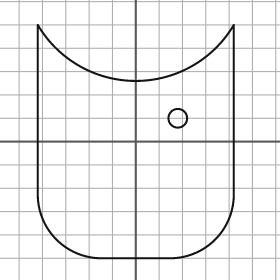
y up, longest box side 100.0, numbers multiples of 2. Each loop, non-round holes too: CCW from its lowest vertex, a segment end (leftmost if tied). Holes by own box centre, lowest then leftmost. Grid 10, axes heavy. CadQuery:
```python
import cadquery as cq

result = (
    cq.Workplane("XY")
    .moveTo(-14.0, -50.0)
    .lineTo(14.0, -50.0)
    .threePointArc((34.0, -42.0), (42.0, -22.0))
    .lineTo(42.0, 50.0)
    .threePointArc((0.0, 26.0), (-42.0, 50.0))
    .lineTo(-42.0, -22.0)
    .threePointArc((-34.0, -42.0), (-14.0, -50.0))
    .close()
    .moveTo(18.0, 10.0)
    .circle(4.0)
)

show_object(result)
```